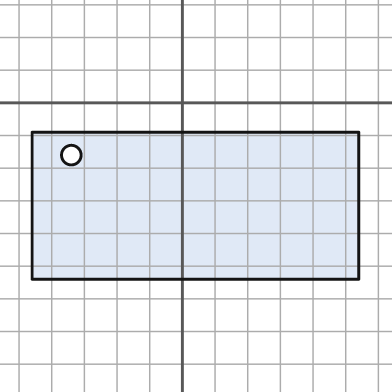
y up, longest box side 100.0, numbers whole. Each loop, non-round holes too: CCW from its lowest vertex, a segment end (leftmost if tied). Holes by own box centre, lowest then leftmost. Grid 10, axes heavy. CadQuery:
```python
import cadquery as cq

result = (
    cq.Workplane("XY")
    .moveTo(-46.0, -54.0)
    .lineTo(54.0, -54.0)
    .lineTo(54.0, -9.0)
    .lineTo(-46.0, -9.0)
    .close()
    .moveTo(-34.0, -16.0)
    .circle(3.0)
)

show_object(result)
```